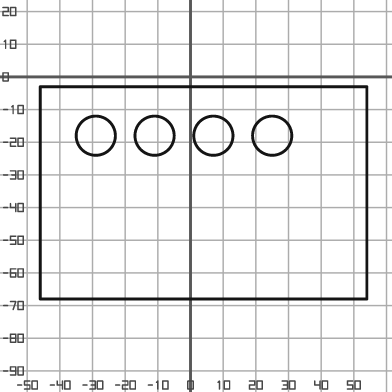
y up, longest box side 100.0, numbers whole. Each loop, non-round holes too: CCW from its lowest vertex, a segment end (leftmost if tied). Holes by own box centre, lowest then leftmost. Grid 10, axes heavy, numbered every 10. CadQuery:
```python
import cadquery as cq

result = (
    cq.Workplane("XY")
    .moveTo(-46.0, -68.0)
    .lineTo(54.0, -68.0)
    .lineTo(54.0, -3.0)
    .lineTo(-46.0, -3.0)
    .close()
    .moveTo(-29.0, -18.0)
    .circle(6.0)
    .moveTo(-11.0, -18.0)
    .circle(6.0)
    .moveTo(7.0, -18.0)
    .circle(6.0)
    .moveTo(25.0, -18.0)
    .circle(6.0)
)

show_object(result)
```